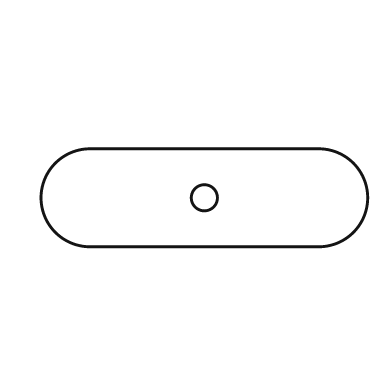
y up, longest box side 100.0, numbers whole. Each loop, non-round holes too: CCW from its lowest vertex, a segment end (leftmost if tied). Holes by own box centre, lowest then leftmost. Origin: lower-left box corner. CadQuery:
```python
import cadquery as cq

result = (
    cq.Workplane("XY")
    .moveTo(15.0, 0.0)
    .lineTo(85.0, 0.0)
    .threePointArc((100.0, 15.0), (85.0, 30.0))
    .lineTo(15.0, 30.0)
    .threePointArc((0.0, 15.0), (15.0, 0.0))
    .close()
    .moveTo(50.0, 15.0)
    .circle(4.0)
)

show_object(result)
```